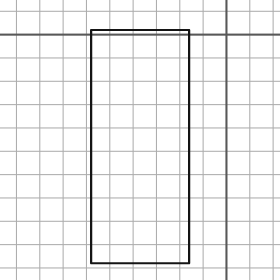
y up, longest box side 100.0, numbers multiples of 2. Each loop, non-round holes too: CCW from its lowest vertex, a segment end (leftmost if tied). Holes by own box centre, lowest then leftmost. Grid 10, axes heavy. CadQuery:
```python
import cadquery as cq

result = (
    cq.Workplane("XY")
    .moveTo(-58.0, -98.0)
    .lineTo(-16.0, -98.0)
    .lineTo(-16.0, 2.0)
    .lineTo(-58.0, 2.0)
    .close()
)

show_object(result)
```